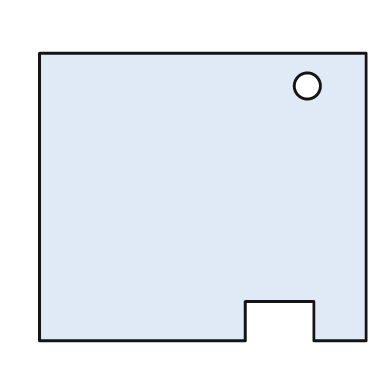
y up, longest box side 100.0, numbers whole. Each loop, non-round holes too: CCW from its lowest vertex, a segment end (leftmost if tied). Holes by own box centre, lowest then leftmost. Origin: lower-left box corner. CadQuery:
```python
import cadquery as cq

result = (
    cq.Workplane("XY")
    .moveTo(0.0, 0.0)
    .lineTo(63.0, 0.0)
    .lineTo(63.0, 12.0)
    .lineTo(84.0, 12.0)
    .lineTo(84.0, 0.0)
    .lineTo(100.0, 0.0)
    .lineTo(100.0, 88.0)
    .lineTo(0.0, 88.0)
    .close()
    .moveTo(82.0, 78.0)
    .circle(4.0)
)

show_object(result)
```